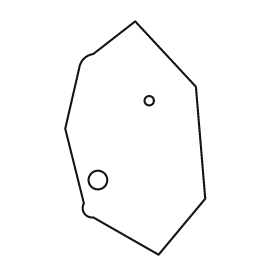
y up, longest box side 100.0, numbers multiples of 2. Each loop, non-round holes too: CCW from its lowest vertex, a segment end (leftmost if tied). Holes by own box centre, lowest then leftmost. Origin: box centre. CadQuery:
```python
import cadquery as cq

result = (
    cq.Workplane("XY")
    .moveTo(10.0, -50.0)
    .lineTo(30.0, -26.0)
    .lineTo(26.0, 22.0)
    .lineTo(0.0, 50.0)
    .lineTo(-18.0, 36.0)
    .threePointArc((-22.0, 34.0), (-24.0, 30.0))
    .lineTo(-30.0, 4.0)
    .lineTo(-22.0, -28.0)
    .threePointArc((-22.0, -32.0), (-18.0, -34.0))
    .close()
    .moveTo(-16.0, -18.0)
    .circle(4.0)
    .moveTo(6.0, 16.0)
    .circle(2.0)
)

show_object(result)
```